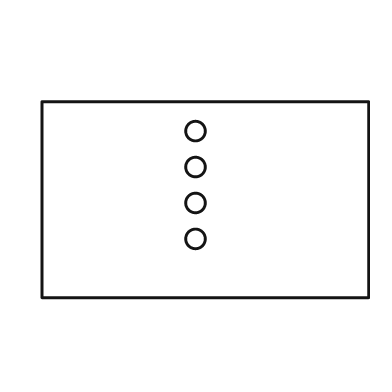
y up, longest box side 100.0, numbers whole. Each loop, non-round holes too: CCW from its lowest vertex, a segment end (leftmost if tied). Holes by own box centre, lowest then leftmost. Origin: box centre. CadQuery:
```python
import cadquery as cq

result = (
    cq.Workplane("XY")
    .moveTo(-50.0, -30.0)
    .lineTo(50.0, -30.0)
    .lineTo(50.0, 30.0)
    .lineTo(-50.0, 30.0)
    .close()
    .moveTo(-3.0, -12.0)
    .circle(3.0)
    .moveTo(-3.0, -1.0)
    .circle(3.0)
    .moveTo(-3.0, 10.0)
    .circle(3.0)
    .moveTo(-3.0, 21.0)
    .circle(3.0)
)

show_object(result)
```